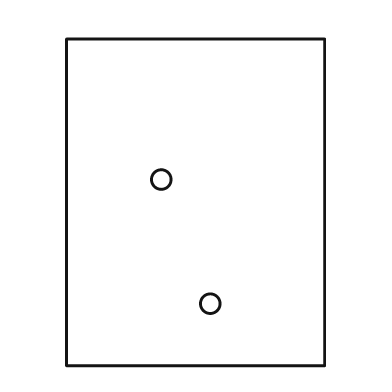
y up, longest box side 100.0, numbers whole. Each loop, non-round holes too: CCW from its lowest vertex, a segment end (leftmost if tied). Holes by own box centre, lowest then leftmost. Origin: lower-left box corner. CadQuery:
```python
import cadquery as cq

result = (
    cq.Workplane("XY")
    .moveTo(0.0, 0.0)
    .lineTo(79.0, 0.0)
    .lineTo(79.0, 100.0)
    .lineTo(0.0, 100.0)
    .close()
    .moveTo(44.0, 19.0)
    .circle(3.0)
    .moveTo(29.0, 57.0)
    .circle(3.0)
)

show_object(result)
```